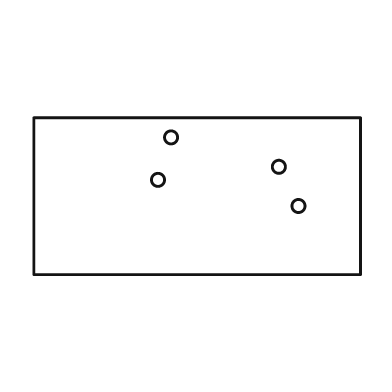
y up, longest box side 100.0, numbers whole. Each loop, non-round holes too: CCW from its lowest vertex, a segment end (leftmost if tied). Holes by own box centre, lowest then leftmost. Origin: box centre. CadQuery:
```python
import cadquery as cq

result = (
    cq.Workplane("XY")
    .moveTo(-50.0, -24.0)
    .lineTo(50.0, -24.0)
    .lineTo(50.0, 24.0)
    .lineTo(-50.0, 24.0)
    .close()
    .moveTo(31.0, -3.0)
    .circle(2.0)
    .moveTo(-12.0, 5.0)
    .circle(2.0)
    .moveTo(25.0, 9.0)
    .circle(2.0)
    .moveTo(-8.0, 18.0)
    .circle(2.0)
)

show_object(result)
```